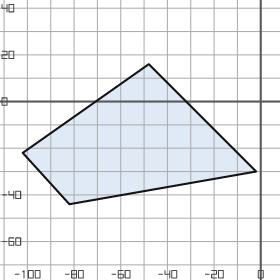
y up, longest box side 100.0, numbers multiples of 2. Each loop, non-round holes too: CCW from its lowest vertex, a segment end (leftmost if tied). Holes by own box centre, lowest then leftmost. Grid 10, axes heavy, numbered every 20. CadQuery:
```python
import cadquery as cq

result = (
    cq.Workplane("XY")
    .moveTo(-82.0, -44.0)
    .lineTo(-2.0, -30.0)
    .lineTo(-48.0, 16.0)
    .lineTo(-102.0, -22.0)
    .close()
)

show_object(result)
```